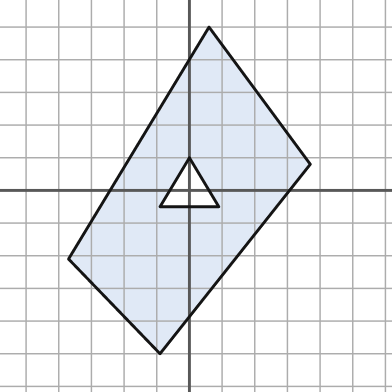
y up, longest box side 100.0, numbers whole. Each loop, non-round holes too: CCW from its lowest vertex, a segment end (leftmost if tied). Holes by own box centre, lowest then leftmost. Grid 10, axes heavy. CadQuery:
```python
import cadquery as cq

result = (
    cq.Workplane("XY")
    .moveTo(-9.0, -50.0)
    .lineTo(37.0, 8.0)
    .lineTo(6.0, 50.0)
    .lineTo(-37.0, -21.0)
    .close()
    .moveTo(-9.0, -5.0)
    .lineTo(9.0, -5.0)
    .lineTo(0.0, 10.0)
    .close()
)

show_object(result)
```